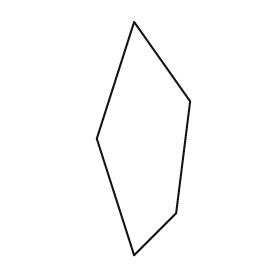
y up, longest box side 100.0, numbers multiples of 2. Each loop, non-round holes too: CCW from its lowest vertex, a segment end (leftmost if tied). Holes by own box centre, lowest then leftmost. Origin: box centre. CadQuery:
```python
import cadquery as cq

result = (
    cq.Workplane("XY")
    .moveTo(-4.0, -50.0)
    .lineTo(14.0, -32.0)
    .lineTo(20.0, 16.0)
    .lineTo(-4.0, 50.0)
    .lineTo(-20.0, 0.0)
    .close()
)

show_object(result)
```